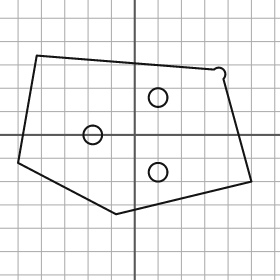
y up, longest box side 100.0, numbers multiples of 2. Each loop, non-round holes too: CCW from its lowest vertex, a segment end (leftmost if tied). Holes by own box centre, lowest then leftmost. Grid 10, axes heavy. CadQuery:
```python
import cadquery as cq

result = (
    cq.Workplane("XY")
    .moveTo(-8.0, -34.0)
    .lineTo(50.0, -20.0)
    .lineTo(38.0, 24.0)
    .threePointArc((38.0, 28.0), (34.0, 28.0))
    .lineTo(-42.0, 34.0)
    .lineTo(-50.0, -12.0)
    .close()
    .moveTo(10.0, -16.0)
    .circle(4.0)
    .moveTo(-18.0, 0.0)
    .circle(4.0)
    .moveTo(10.0, 16.0)
    .circle(4.0)
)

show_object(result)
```